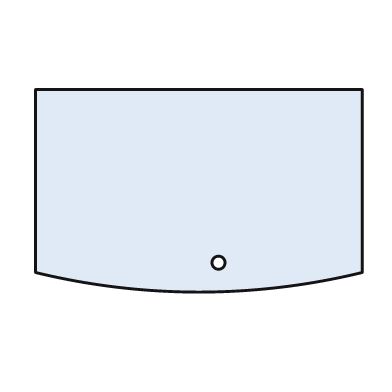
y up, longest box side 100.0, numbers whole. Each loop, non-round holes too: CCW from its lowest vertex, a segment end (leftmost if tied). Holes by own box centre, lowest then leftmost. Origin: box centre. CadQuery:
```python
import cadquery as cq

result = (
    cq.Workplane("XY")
    .moveTo(-50.0, -25.0)
    .threePointArc((0.0, -31.0), (50.0, -25.0))
    .lineTo(50.0, 31.0)
    .lineTo(-50.0, 31.0)
    .close()
    .moveTo(6.0, -22.0)
    .circle(2.0)
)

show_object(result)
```